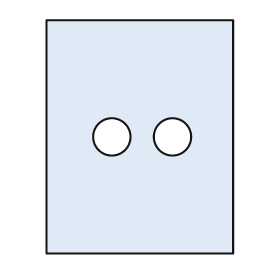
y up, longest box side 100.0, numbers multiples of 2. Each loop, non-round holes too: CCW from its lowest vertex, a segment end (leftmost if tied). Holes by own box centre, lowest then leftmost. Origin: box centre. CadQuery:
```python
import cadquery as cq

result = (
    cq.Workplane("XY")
    .moveTo(-40.0, -50.0)
    .lineTo(40.0, -50.0)
    .lineTo(40.0, 50.0)
    .lineTo(-40.0, 50.0)
    .close()
    .moveTo(-12.0, 0.0)
    .circle(8.0)
    .moveTo(14.0, 0.0)
    .circle(8.0)
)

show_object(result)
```